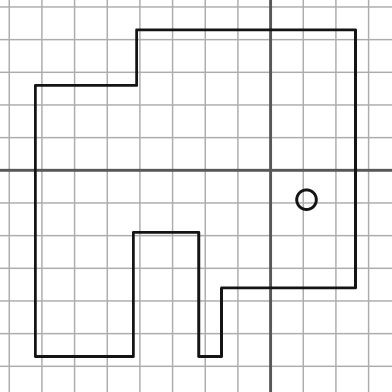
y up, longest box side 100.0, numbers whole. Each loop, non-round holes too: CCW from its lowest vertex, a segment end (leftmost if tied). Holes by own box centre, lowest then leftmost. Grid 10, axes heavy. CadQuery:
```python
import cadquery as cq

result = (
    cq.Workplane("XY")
    .moveTo(-72.0, -57.0)
    .lineTo(-42.0, -57.0)
    .lineTo(-42.0, -19.0)
    .lineTo(-22.0, -19.0)
    .lineTo(-22.0, -57.0)
    .lineTo(-15.0, -57.0)
    .lineTo(-15.0, -36.0)
    .lineTo(26.0, -36.0)
    .lineTo(26.0, 43.0)
    .lineTo(-41.0, 43.0)
    .lineTo(-41.0, 26.0)
    .lineTo(-72.0, 26.0)
    .close()
    .moveTo(11.0, -9.0)
    .circle(3.0)
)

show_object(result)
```